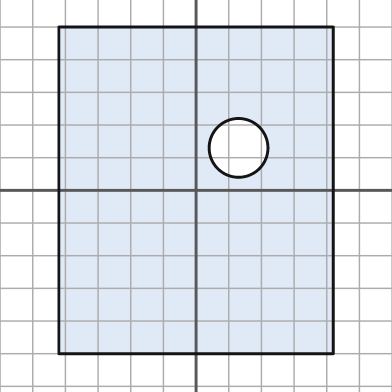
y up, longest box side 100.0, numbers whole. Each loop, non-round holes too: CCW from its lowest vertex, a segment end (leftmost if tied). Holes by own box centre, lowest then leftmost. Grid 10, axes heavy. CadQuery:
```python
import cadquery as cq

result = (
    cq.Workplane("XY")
    .moveTo(-42.0, -50.0)
    .lineTo(42.0, -50.0)
    .lineTo(42.0, 50.0)
    .lineTo(-42.0, 50.0)
    .close()
    .moveTo(13.0, 13.0)
    .circle(9.0)
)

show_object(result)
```